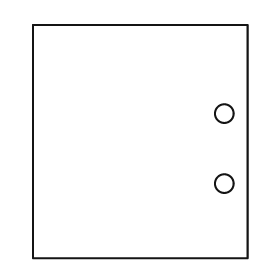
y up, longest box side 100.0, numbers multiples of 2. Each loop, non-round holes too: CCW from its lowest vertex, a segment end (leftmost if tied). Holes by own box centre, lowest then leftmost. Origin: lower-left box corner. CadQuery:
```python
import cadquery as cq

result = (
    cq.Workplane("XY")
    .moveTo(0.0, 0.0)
    .lineTo(92.0, 0.0)
    .lineTo(92.0, 100.0)
    .lineTo(0.0, 100.0)
    .close()
    .moveTo(82.0, 32.0)
    .circle(4.0)
    .moveTo(82.0, 62.0)
    .circle(4.0)
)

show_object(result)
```